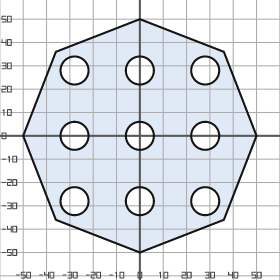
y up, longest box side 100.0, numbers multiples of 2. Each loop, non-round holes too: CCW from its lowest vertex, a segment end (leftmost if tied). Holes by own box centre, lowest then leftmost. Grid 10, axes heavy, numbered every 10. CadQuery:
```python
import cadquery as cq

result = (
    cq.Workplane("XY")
    .moveTo(0.0, -50.0)
    .lineTo(36.0, -36.0)
    .lineTo(50.0, 0.0)
    .lineTo(36.0, 36.0)
    .lineTo(0.0, 50.0)
    .lineTo(-36.0, 36.0)
    .lineTo(-50.0, 0.0)
    .lineTo(-36.0, -36.0)
    .close()
    .moveTo(-28.0, -28.0)
    .circle(6.0)
    .moveTo(0.0, -28.0)
    .circle(6.0)
    .moveTo(28.0, -28.0)
    .circle(6.0)
    .moveTo(-28.0, 0.0)
    .circle(6.0)
    .moveTo(0.0, 0.0)
    .circle(6.0)
    .moveTo(28.0, 0.0)
    .circle(6.0)
    .moveTo(-28.0, 28.0)
    .circle(6.0)
    .moveTo(0.0, 28.0)
    .circle(6.0)
    .moveTo(28.0, 28.0)
    .circle(6.0)
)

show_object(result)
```